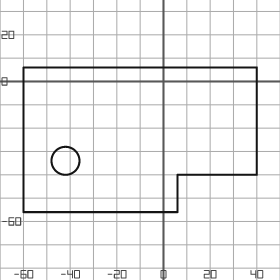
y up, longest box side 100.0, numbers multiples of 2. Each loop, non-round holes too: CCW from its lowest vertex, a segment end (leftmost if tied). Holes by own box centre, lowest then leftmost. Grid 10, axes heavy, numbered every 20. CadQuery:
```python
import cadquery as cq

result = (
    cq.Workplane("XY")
    .moveTo(-60.0, -56.0)
    .lineTo(6.0, -56.0)
    .lineTo(6.0, -40.0)
    .lineTo(40.0, -40.0)
    .lineTo(40.0, 6.0)
    .lineTo(-60.0, 6.0)
    .close()
    .moveTo(-42.0, -34.0)
    .circle(6.0)
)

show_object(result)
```